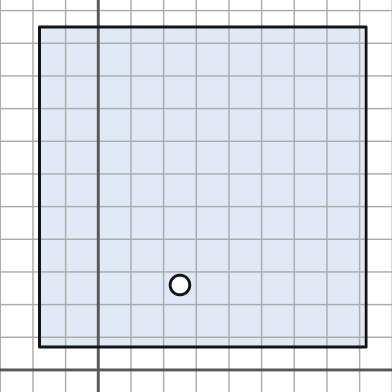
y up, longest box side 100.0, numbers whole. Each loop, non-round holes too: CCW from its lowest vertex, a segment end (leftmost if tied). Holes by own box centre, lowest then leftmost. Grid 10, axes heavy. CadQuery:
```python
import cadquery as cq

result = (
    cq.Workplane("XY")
    .moveTo(-18.0, 7.0)
    .lineTo(82.0, 7.0)
    .lineTo(82.0, 105.0)
    .lineTo(-18.0, 105.0)
    .close()
    .moveTo(25.0, 26.0)
    .circle(3.0)
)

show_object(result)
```